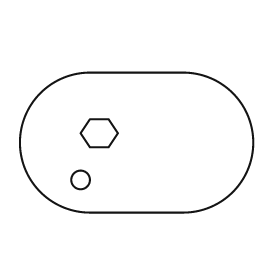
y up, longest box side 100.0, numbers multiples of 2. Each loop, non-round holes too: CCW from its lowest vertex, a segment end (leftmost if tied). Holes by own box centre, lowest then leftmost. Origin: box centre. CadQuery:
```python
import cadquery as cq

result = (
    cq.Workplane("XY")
    .moveTo(-20.0, -30.0)
    .lineTo(20.0, -30.0)
    .threePointArc((50.0, 0.0), (20.0, 30.0))
    .lineTo(-20.0, 30.0)
    .threePointArc((-50.0, 0.0), (-20.0, -30.0))
    .close()
    .moveTo(-24.0, -16.0)
    .circle(4.0)
    .moveTo(-20.0, -2.0)
    .lineTo(-12.0, -2.0)
    .lineTo(-8.0, 4.0)
    .lineTo(-12.0, 10.0)
    .lineTo(-20.0, 10.0)
    .lineTo(-24.0, 4.0)
    .close()
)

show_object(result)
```